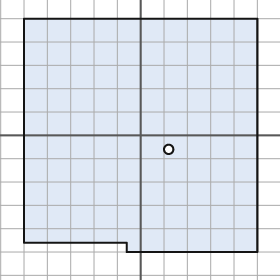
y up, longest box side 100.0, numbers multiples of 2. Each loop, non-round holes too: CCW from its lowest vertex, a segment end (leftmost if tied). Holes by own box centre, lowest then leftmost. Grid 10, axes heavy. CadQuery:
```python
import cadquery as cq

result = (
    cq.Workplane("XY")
    .moveTo(-6.0, -50.0)
    .lineTo(50.0, -50.0)
    .lineTo(50.0, 50.0)
    .lineTo(-50.0, 50.0)
    .lineTo(-50.0, -46.0)
    .lineTo(-6.0, -46.0)
    .close()
    .moveTo(12.0, -6.0)
    .circle(2.0)
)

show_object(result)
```